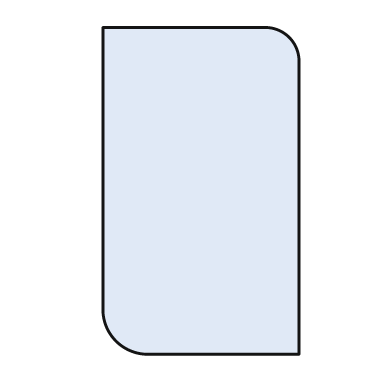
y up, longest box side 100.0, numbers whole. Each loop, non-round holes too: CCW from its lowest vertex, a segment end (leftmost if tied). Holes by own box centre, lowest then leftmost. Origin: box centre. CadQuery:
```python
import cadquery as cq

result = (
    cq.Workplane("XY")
    .moveTo(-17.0, -50.0)
    .lineTo(30.0, -50.0)
    .lineTo(30.0, 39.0)
    .threePointArc((27.0, 47.0), (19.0, 50.0))
    .lineTo(-30.0, 50.0)
    .lineTo(-30.0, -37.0)
    .threePointArc((-26.0, -46.0), (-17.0, -50.0))
    .close()
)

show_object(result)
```